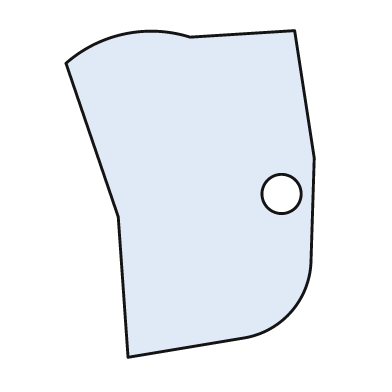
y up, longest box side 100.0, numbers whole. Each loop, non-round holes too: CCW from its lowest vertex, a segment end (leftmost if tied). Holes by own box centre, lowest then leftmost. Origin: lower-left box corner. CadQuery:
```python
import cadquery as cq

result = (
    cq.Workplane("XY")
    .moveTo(19.0, 0.0)
    .lineTo(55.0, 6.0)
    .threePointArc((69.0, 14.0), (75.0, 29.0))
    .lineTo(76.0, 61.0)
    .lineTo(70.0, 100.0)
    .lineTo(38.0, 98.0)
    .threePointArc((18.0, 99.0), (0.0, 90.0))
    .lineTo(16.0, 43.0)
    .close()
    .moveTo(66.0, 50.0)
    .circle(6.0)
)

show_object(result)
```